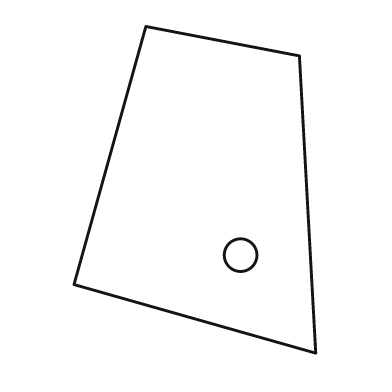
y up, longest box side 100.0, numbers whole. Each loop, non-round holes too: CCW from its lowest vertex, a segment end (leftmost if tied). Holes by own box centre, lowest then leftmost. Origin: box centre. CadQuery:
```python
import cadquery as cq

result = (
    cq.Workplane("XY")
    .moveTo(37.0, -50.0)
    .lineTo(32.0, 41.0)
    .lineTo(-15.0, 50.0)
    .lineTo(-37.0, -29.0)
    .close()
    .moveTo(14.0, -20.0)
    .circle(5.0)
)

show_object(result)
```